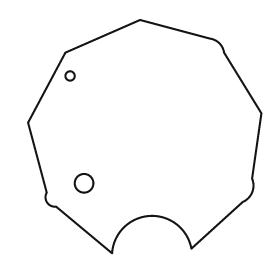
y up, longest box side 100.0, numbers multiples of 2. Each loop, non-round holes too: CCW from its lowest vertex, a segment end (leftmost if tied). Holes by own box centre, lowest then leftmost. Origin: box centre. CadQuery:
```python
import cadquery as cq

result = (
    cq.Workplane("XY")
    .moveTo(-14.0, -50.0)
    .threePointArc((2.0, -34.0), (20.0, -48.0))
    .lineTo(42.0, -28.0)
    .threePointArc((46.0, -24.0), (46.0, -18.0))
    .lineTo(50.0, 10.0)
    .lineTo(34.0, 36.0)
    .threePointArc((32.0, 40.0), (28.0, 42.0))
    .lineTo(-2.0, 50.0)
    .lineTo(-34.0, 36.0)
    .lineTo(-50.0, 6.0)
    .lineTo(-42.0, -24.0)
    .threePointArc((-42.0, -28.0), (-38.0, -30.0))
    .close()
    .moveTo(-26.0, -20.0)
    .circle(4.0)
    .moveTo(-32.0, 26.0)
    .circle(2.0)
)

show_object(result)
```